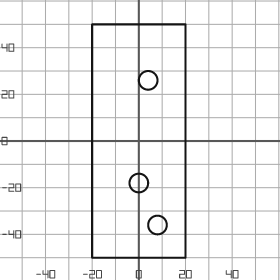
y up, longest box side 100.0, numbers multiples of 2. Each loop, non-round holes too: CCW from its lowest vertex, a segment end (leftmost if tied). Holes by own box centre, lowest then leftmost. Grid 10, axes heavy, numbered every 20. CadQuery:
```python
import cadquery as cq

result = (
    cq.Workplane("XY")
    .moveTo(-20.0, -50.0)
    .lineTo(20.0, -50.0)
    .lineTo(20.0, 50.0)
    .lineTo(-20.0, 50.0)
    .close()
    .moveTo(8.0, -36.0)
    .circle(4.0)
    .moveTo(0.0, -18.0)
    .circle(4.0)
    .moveTo(4.0, 26.0)
    .circle(4.0)
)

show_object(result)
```